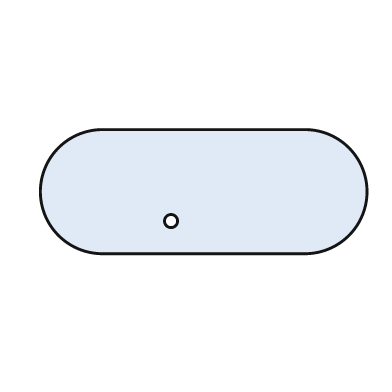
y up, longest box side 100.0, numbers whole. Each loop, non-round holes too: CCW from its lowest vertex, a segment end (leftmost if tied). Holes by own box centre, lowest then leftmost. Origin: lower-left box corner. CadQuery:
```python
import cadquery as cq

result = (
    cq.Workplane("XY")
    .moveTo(19.0, 0.0)
    .lineTo(81.0, 0.0)
    .threePointArc((100.0, 19.0), (81.0, 38.0))
    .lineTo(19.0, 38.0)
    .threePointArc((0.0, 19.0), (19.0, 0.0))
    .close()
    .moveTo(40.0, 10.0)
    .circle(2.0)
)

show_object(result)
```